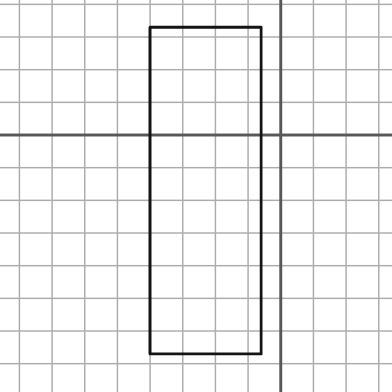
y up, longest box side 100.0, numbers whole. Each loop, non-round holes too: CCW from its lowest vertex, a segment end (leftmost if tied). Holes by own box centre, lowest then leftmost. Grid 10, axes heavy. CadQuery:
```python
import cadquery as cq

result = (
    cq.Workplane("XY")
    .moveTo(-40.0, -67.0)
    .lineTo(-6.0, -67.0)
    .lineTo(-6.0, 33.0)
    .lineTo(-40.0, 33.0)
    .close()
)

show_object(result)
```